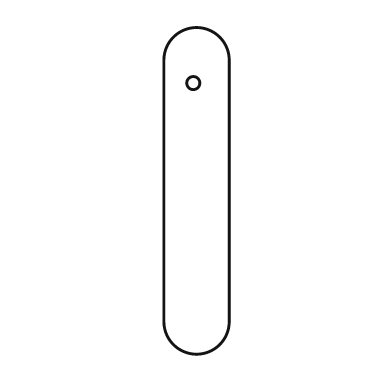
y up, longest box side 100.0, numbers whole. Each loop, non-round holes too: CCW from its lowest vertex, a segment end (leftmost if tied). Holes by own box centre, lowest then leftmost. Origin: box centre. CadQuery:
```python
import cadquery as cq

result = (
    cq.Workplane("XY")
    .moveTo(-10.0, -40.0)
    .threePointArc((0.0, -50.0), (10.0, -40.0))
    .lineTo(10.0, 40.0)
    .threePointArc((0.0, 50.0), (-10.0, 40.0))
    .close()
    .moveTo(-1.0, 33.0)
    .circle(2.0)
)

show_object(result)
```